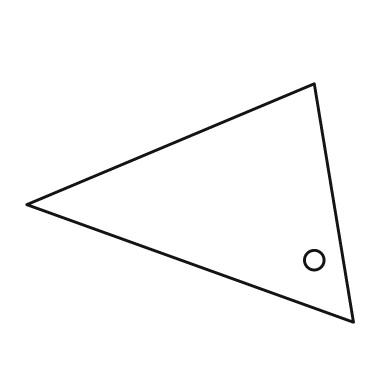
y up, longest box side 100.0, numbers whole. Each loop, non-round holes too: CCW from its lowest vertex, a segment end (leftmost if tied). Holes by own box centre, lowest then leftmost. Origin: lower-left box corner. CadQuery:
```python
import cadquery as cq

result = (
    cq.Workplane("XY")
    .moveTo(100.0, 0.0)
    .lineTo(88.0, 73.0)
    .lineTo(0.0, 36.0)
    .close()
    .moveTo(88.0, 19.0)
    .circle(3.0)
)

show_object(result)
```